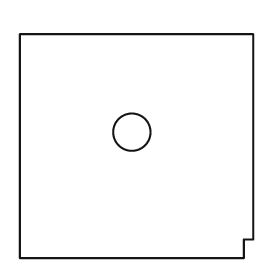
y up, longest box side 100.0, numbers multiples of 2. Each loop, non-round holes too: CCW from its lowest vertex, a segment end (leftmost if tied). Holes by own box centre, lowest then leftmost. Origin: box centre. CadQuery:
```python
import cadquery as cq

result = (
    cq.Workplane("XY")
    .moveTo(-50.0, -48.0)
    .lineTo(46.0, -48.0)
    .lineTo(46.0, -40.0)
    .lineTo(50.0, -40.0)
    .lineTo(50.0, 48.0)
    .lineTo(-50.0, 48.0)
    .close()
    .moveTo(-2.0, 6.0)
    .circle(8.0)
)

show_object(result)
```